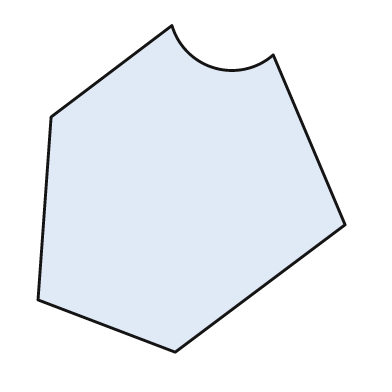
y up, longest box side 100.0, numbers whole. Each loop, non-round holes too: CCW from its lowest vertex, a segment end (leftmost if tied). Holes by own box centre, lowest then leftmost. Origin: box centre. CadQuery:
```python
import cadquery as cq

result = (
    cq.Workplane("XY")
    .moveTo(-5.0, -50.0)
    .lineTo(47.0, -11.0)
    .lineTo(25.0, 41.0)
    .threePointArc((7.0, 37.0), (-6.0, 50.0))
    .lineTo(-43.0, 22.0)
    .lineTo(-47.0, -34.0)
    .close()
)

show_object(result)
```